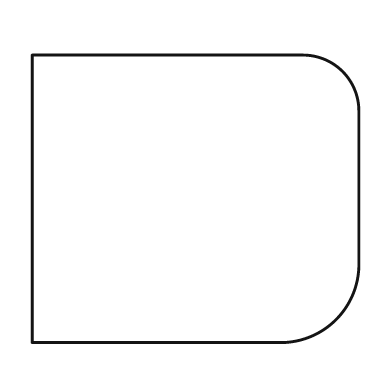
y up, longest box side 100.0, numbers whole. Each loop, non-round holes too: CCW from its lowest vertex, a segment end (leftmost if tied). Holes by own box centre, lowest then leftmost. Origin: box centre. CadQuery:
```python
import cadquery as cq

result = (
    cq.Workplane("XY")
    .moveTo(-50.0, -44.0)
    .lineTo(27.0, -44.0)
    .threePointArc((43.0, -37.0), (50.0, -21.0))
    .lineTo(50.0, 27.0)
    .threePointArc((45.0, 39.0), (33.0, 44.0))
    .lineTo(-50.0, 44.0)
    .close()
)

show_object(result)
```